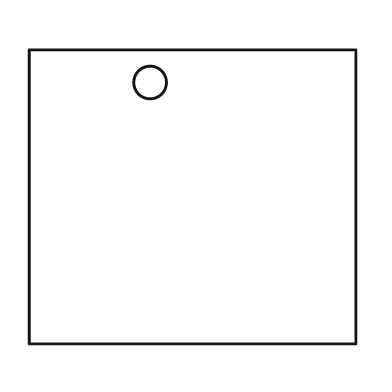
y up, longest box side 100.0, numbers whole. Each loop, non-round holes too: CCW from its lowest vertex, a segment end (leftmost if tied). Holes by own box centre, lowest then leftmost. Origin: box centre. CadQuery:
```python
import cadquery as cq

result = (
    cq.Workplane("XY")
    .moveTo(-50.0, -45.0)
    .lineTo(50.0, -45.0)
    .lineTo(50.0, 45.0)
    .lineTo(-50.0, 45.0)
    .close()
    .moveTo(-13.0, 35.0)
    .circle(5.0)
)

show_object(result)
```